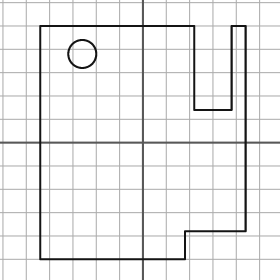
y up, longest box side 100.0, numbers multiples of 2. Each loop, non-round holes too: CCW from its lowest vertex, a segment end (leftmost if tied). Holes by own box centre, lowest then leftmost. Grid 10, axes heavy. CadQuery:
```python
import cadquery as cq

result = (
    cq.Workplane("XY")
    .moveTo(-44.0, -50.0)
    .lineTo(18.0, -50.0)
    .lineTo(18.0, -38.0)
    .lineTo(44.0, -38.0)
    .lineTo(44.0, 50.0)
    .lineTo(38.0, 50.0)
    .lineTo(38.0, 14.0)
    .lineTo(22.0, 14.0)
    .lineTo(22.0, 50.0)
    .lineTo(-44.0, 50.0)
    .close()
    .moveTo(-26.0, 38.0)
    .circle(6.0)
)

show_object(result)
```